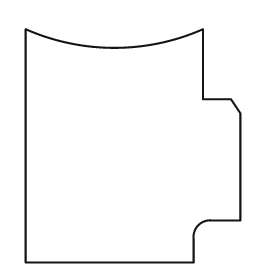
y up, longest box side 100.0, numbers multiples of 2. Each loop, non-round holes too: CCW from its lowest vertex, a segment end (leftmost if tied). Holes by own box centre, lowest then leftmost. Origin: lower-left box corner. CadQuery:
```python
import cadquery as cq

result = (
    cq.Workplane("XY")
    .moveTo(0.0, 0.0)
    .lineTo(72.0, 0.0)
    .lineTo(72.0, 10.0)
    .threePointArc((74.0, 16.0), (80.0, 18.0))
    .lineTo(92.0, 18.0)
    .lineTo(92.0, 64.0)
    .lineTo(88.0, 70.0)
    .lineTo(76.0, 70.0)
    .lineTo(76.0, 100.0)
    .threePointArc((38.0, 92.0), (0.0, 100.0))
    .close()
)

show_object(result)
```